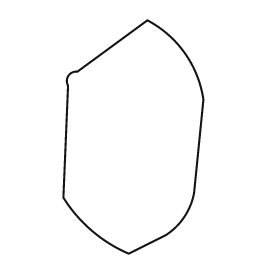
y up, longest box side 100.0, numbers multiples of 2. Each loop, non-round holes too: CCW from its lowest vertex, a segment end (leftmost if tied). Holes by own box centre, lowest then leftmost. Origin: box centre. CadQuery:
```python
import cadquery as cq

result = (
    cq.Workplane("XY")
    .moveTo(-2.0, -50.0)
    .lineTo(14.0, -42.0)
    .threePointArc((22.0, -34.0), (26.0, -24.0))
    .lineTo(30.0, 16.0)
    .threePointArc((22.0, 36.0), (6.0, 50.0))
    .lineTo(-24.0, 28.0)
    .threePointArc((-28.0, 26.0), (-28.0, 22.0))
    .lineTo(-30.0, -26.0)
    .threePointArc((-18.0, -40.0), (-2.0, -50.0))
    .close()
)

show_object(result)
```